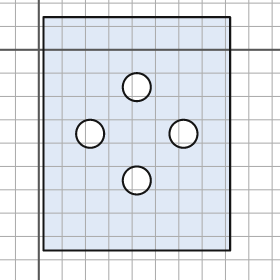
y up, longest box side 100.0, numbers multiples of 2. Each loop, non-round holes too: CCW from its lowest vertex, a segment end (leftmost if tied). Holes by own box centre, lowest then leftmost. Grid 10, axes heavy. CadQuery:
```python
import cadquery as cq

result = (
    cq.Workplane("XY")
    .moveTo(2.0, -86.0)
    .lineTo(82.0, -86.0)
    .lineTo(82.0, 14.0)
    .lineTo(2.0, 14.0)
    .close()
    .moveTo(42.0, -56.0)
    .circle(6.0)
    .moveTo(22.0, -36.0)
    .circle(6.0)
    .moveTo(62.0, -36.0)
    .circle(6.0)
    .moveTo(42.0, -16.0)
    .circle(6.0)
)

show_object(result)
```